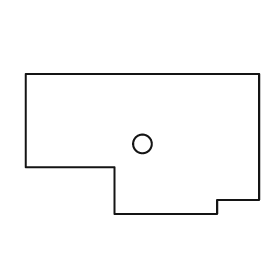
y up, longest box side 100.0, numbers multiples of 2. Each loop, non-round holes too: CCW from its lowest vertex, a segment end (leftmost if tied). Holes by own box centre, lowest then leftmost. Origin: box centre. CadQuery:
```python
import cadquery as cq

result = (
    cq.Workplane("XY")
    .moveTo(-12.0, -30.0)
    .lineTo(32.0, -30.0)
    .lineTo(32.0, -24.0)
    .lineTo(50.0, -24.0)
    .lineTo(50.0, 30.0)
    .lineTo(-50.0, 30.0)
    .lineTo(-50.0, -10.0)
    .lineTo(-12.0, -10.0)
    .close()
    .moveTo(0.0, 0.0)
    .circle(4.0)
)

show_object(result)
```